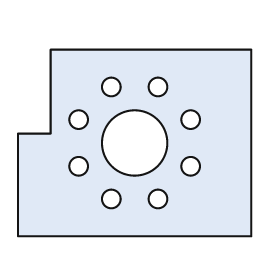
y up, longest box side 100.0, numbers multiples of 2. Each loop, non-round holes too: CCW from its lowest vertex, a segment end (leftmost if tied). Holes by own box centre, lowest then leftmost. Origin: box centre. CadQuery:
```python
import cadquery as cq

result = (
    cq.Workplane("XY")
    .moveTo(-50.0, -40.0)
    .lineTo(50.0, -40.0)
    .lineTo(50.0, 40.0)
    .lineTo(-36.0, 40.0)
    .lineTo(-36.0, 4.0)
    .lineTo(-50.0, 4.0)
    .close()
    .moveTo(-10.0, -24.0)
    .circle(4.0)
    .moveTo(10.0, -24.0)
    .circle(4.0)
    .moveTo(-24.0, -10.0)
    .circle(4.0)
    .moveTo(24.0, -10.0)
    .circle(4.0)
    .moveTo(0.0, 0.0)
    .circle(14.0)
    .moveTo(-24.0, 10.0)
    .circle(4.0)
    .moveTo(24.0, 10.0)
    .circle(4.0)
    .moveTo(-10.0, 24.0)
    .circle(4.0)
    .moveTo(10.0, 24.0)
    .circle(4.0)
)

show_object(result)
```